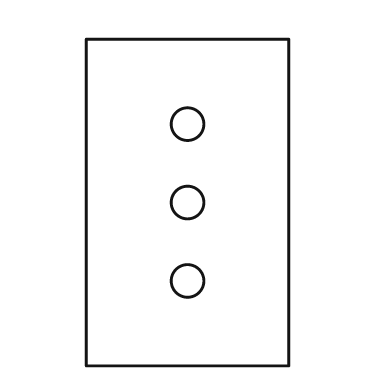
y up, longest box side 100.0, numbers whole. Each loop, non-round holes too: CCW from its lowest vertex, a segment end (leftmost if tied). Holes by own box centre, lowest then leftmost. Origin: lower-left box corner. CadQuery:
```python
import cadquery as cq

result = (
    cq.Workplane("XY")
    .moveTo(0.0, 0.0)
    .lineTo(62.0, 0.0)
    .lineTo(62.0, 100.0)
    .lineTo(0.0, 100.0)
    .close()
    .moveTo(31.0, 26.0)
    .circle(5.0)
    .moveTo(31.0, 50.0)
    .circle(5.0)
    .moveTo(31.0, 74.0)
    .circle(5.0)
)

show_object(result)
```